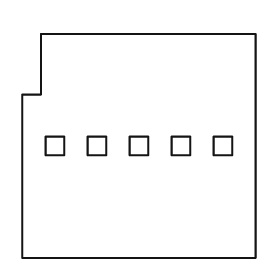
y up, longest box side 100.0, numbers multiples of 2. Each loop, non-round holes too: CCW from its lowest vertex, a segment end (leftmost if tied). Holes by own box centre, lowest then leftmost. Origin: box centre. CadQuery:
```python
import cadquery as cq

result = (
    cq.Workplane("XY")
    .moveTo(-50.0, -48.0)
    .lineTo(50.0, -48.0)
    .lineTo(50.0, 48.0)
    .lineTo(-42.0, 48.0)
    .lineTo(-42.0, 22.0)
    .lineTo(-50.0, 22.0)
    .close()
    .moveTo(-40.0, -4.0)
    .lineTo(-32.0, -4.0)
    .lineTo(-32.0, 4.0)
    .lineTo(-40.0, 4.0)
    .close()
    .moveTo(-22.0, -4.0)
    .lineTo(-14.0, -4.0)
    .lineTo(-14.0, 4.0)
    .lineTo(-22.0, 4.0)
    .close()
    .moveTo(-4.0, -4.0)
    .lineTo(4.0, -4.0)
    .lineTo(4.0, 4.0)
    .lineTo(-4.0, 4.0)
    .close()
    .moveTo(14.0, -4.0)
    .lineTo(22.0, -4.0)
    .lineTo(22.0, 4.0)
    .lineTo(14.0, 4.0)
    .close()
    .moveTo(32.0, -4.0)
    .lineTo(40.0, -4.0)
    .lineTo(40.0, 4.0)
    .lineTo(32.0, 4.0)
    .close()
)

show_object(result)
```